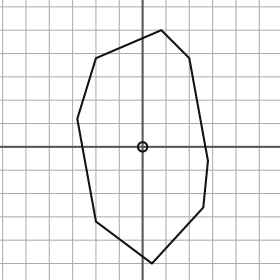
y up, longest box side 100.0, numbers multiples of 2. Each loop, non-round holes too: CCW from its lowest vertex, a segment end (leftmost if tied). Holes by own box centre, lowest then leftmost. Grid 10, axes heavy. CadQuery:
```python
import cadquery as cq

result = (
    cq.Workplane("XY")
    .moveTo(4.0, -50.0)
    .lineTo(26.0, -26.0)
    .lineTo(28.0, -6.0)
    .lineTo(20.0, 38.0)
    .lineTo(8.0, 50.0)
    .lineTo(-20.0, 38.0)
    .lineTo(-28.0, 12.0)
    .lineTo(-20.0, -32.0)
    .close()
    .moveTo(0.0, 0.0)
    .circle(2.0)
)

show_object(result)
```